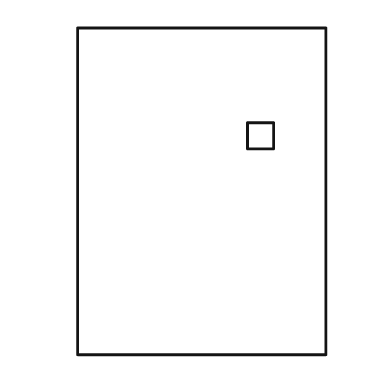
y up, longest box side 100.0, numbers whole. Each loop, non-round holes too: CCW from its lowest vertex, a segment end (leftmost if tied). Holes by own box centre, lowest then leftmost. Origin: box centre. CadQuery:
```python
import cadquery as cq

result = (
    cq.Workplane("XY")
    .moveTo(-38.0, -50.0)
    .lineTo(38.0, -50.0)
    .lineTo(38.0, 50.0)
    .lineTo(-38.0, 50.0)
    .close()
    .moveTo(14.0, 13.0)
    .lineTo(22.0, 13.0)
    .lineTo(22.0, 21.0)
    .lineTo(14.0, 21.0)
    .close()
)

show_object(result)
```